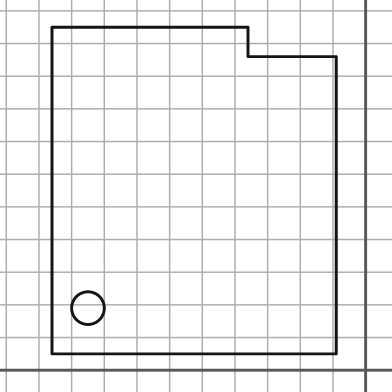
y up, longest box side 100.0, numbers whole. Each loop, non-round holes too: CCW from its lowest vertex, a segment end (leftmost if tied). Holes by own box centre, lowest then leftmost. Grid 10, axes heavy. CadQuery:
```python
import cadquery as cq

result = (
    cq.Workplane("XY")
    .moveTo(-96.0, 5.0)
    .lineTo(-9.0, 5.0)
    .lineTo(-9.0, 96.0)
    .lineTo(-36.0, 96.0)
    .lineTo(-36.0, 105.0)
    .lineTo(-96.0, 105.0)
    .close()
    .moveTo(-85.0, 19.0)
    .circle(5.0)
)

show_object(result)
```